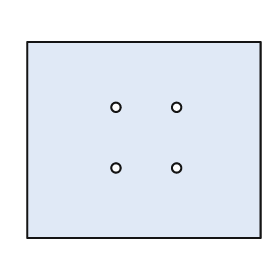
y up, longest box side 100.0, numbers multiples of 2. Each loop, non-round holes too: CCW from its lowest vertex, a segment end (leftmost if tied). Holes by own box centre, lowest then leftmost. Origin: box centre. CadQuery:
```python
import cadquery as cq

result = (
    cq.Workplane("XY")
    .moveTo(-50.0, -42.0)
    .lineTo(50.0, -42.0)
    .lineTo(50.0, 42.0)
    .lineTo(-50.0, 42.0)
    .close()
    .moveTo(-12.0, -12.0)
    .circle(2.0)
    .moveTo(14.0, -12.0)
    .circle(2.0)
    .moveTo(-12.0, 14.0)
    .circle(2.0)
    .moveTo(14.0, 14.0)
    .circle(2.0)
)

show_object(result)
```